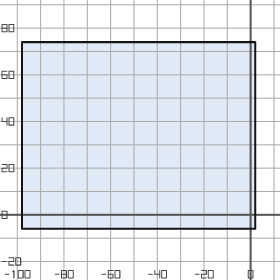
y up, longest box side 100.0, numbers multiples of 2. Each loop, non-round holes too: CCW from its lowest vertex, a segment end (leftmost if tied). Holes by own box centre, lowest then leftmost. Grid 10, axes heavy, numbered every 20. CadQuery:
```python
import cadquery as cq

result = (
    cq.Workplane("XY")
    .moveTo(-98.0, -6.0)
    .lineTo(2.0, -6.0)
    .lineTo(2.0, 74.0)
    .lineTo(-98.0, 74.0)
    .close()
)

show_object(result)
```